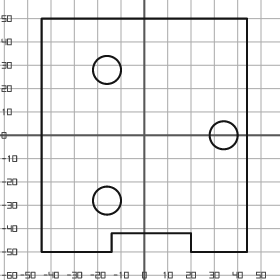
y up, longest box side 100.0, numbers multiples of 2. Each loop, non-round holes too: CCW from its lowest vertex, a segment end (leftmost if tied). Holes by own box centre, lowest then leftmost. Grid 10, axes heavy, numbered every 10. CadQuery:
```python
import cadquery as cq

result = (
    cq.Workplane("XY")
    .moveTo(-44.0, -50.0)
    .lineTo(-14.0, -50.0)
    .lineTo(-14.0, -42.0)
    .lineTo(20.0, -42.0)
    .lineTo(20.0, -50.0)
    .lineTo(44.0, -50.0)
    .lineTo(44.0, 50.0)
    .lineTo(-44.0, 50.0)
    .close()
    .moveTo(-16.0, -28.0)
    .circle(6.0)
    .moveTo(34.0, 0.0)
    .circle(6.0)
    .moveTo(-16.0, 28.0)
    .circle(6.0)
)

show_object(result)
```